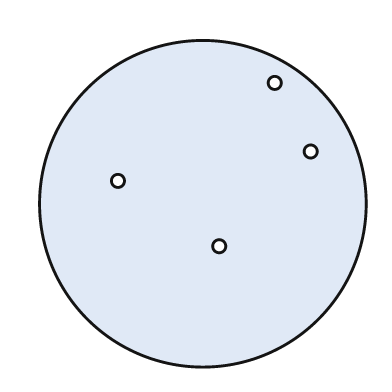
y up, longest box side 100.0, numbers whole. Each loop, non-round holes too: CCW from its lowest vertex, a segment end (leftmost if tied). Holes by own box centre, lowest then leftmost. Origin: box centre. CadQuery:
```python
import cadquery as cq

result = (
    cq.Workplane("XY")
    .moveTo(0.0, 0.0)
    .circle(50.0)
    .moveTo(5.0, -13.0)
    .circle(2.0)
    .moveTo(-26.0, 7.0)
    .circle(2.0)
    .moveTo(33.0, 16.0)
    .circle(2.0)
    .moveTo(22.0, 37.0)
    .circle(2.0)
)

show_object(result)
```